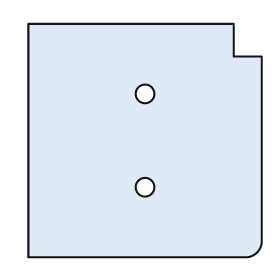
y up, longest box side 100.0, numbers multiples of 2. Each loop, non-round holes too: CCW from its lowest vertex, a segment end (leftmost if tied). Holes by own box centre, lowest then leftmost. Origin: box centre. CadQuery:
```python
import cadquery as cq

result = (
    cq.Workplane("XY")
    .moveTo(-50.0, -50.0)
    .lineTo(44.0, -50.0)
    .threePointArc((48.0, -48.0), (50.0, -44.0))
    .lineTo(50.0, 36.0)
    .lineTo(38.0, 36.0)
    .lineTo(38.0, 50.0)
    .lineTo(-50.0, 50.0)
    .close()
    .moveTo(0.0, -20.0)
    .circle(4.0)
    .moveTo(0.0, 20.0)
    .circle(4.0)
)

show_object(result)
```